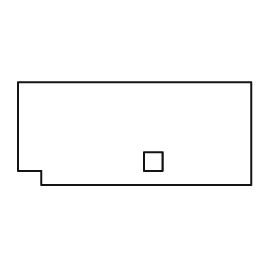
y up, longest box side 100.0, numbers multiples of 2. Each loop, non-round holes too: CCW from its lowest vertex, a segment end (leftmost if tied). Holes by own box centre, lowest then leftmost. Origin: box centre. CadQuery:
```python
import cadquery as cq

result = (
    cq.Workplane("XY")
    .moveTo(-40.0, -22.0)
    .lineTo(50.0, -22.0)
    .lineTo(50.0, 22.0)
    .lineTo(-50.0, 22.0)
    .lineTo(-50.0, -16.0)
    .lineTo(-40.0, -16.0)
    .close()
    .moveTo(4.0, -16.0)
    .lineTo(12.0, -16.0)
    .lineTo(12.0, -8.0)
    .lineTo(4.0, -8.0)
    .close()
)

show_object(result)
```